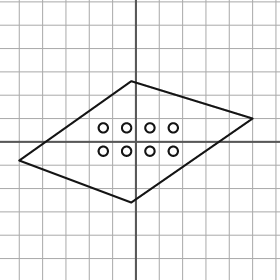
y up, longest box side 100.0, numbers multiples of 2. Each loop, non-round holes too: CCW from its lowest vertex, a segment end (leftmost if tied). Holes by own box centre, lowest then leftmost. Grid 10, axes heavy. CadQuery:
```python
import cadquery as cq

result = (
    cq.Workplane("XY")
    .moveTo(-2.0, -26.0)
    .lineTo(50.0, 10.0)
    .lineTo(-2.0, 26.0)
    .lineTo(-50.0, -8.0)
    .close()
    .moveTo(-14.0, -4.0)
    .circle(2.0)
    .moveTo(-4.0, -4.0)
    .circle(2.0)
    .moveTo(6.0, -4.0)
    .circle(2.0)
    .moveTo(16.0, -4.0)
    .circle(2.0)
    .moveTo(-14.0, 6.0)
    .circle(2.0)
    .moveTo(-4.0, 6.0)
    .circle(2.0)
    .moveTo(6.0, 6.0)
    .circle(2.0)
    .moveTo(16.0, 6.0)
    .circle(2.0)
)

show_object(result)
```